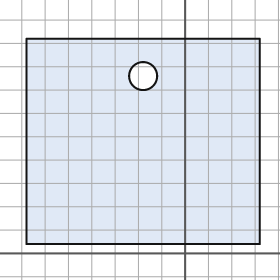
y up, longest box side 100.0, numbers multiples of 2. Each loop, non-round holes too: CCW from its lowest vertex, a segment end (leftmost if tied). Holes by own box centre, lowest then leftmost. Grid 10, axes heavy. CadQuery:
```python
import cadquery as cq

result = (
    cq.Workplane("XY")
    .moveTo(-68.0, 4.0)
    .lineTo(32.0, 4.0)
    .lineTo(32.0, 92.0)
    .lineTo(-68.0, 92.0)
    .close()
    .moveTo(-18.0, 76.0)
    .circle(6.0)
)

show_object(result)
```